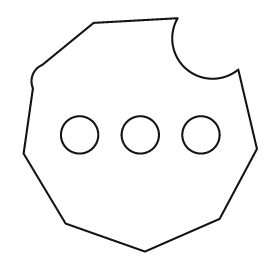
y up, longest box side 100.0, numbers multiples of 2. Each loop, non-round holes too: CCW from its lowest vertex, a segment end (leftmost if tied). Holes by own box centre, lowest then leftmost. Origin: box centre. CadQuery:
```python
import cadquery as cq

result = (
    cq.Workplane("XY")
    .moveTo(2.0, -50.0)
    .lineTo(34.0, -36.0)
    .lineTo(50.0, -6.0)
    .lineTo(42.0, 28.0)
    .threePointArc((20.0, 28.0), (16.0, 50.0))
    .lineTo(-20.0, 48.0)
    .lineTo(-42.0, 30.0)
    .threePointArc((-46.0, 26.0), (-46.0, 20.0))
    .lineTo(-50.0, -8.0)
    .lineTo(-32.0, -38.0)
    .close()
    .moveTo(-26.0, 0.0)
    .circle(8.0)
    .moveTo(0.0, 0.0)
    .circle(8.0)
    .moveTo(26.0, 0.0)
    .circle(8.0)
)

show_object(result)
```